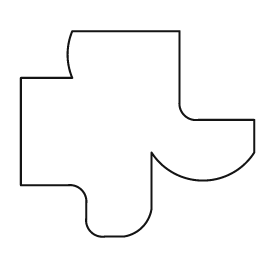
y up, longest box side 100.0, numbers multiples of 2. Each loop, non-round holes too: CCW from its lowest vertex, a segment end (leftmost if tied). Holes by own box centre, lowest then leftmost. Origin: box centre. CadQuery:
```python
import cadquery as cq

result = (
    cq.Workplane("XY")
    .moveTo(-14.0, -44.0)
    .lineTo(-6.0, -44.0)
    .threePointArc((2.0, -40.0), (6.0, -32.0))
    .lineTo(6.0, -8.0)
    .threePointArc((28.0, -20.0), (50.0, -8.0))
    .lineTo(50.0, 6.0)
    .lineTo(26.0, 6.0)
    .threePointArc((20.0, 8.0), (18.0, 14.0))
    .lineTo(18.0, 44.0)
    .lineTo(-28.0, 44.0)
    .threePointArc((-30.0, 34.0), (-28.0, 24.0))
    .lineTo(-50.0, 24.0)
    .lineTo(-50.0, -22.0)
    .lineTo(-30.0, -22.0)
    .threePointArc((-24.0, -24.0), (-22.0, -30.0))
    .lineTo(-22.0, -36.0)
    .threePointArc((-20.0, -42.0), (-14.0, -44.0))
    .close()
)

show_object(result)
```